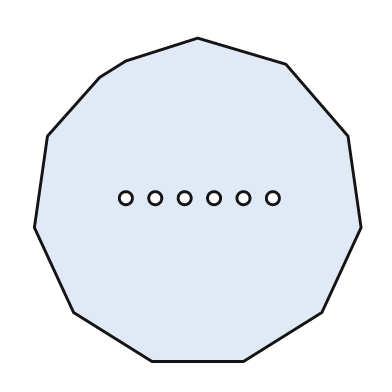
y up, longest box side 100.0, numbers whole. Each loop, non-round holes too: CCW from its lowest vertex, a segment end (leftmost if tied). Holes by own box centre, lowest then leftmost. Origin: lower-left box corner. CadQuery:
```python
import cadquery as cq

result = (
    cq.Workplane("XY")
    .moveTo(36.0, 0.0)
    .lineTo(64.0, 0.0)
    .lineTo(88.0, 15.0)
    .lineTo(100.0, 41.0)
    .lineTo(96.0, 69.0)
    .lineTo(77.0, 91.0)
    .lineTo(50.0, 99.0)
    .lineTo(28.0, 92.0)
    .lineTo(20.0, 87.0)
    .lineTo(4.0, 69.0)
    .lineTo(0.0, 41.0)
    .lineTo(12.0, 15.0)
    .close()
    .moveTo(28.0, 50.0)
    .circle(2.0)
    .moveTo(37.0, 50.0)
    .circle(2.0)
    .moveTo(46.0, 50.0)
    .circle(2.0)
    .moveTo(55.0, 50.0)
    .circle(2.0)
    .moveTo(64.0, 50.0)
    .circle(2.0)
    .moveTo(73.0, 50.0)
    .circle(2.0)
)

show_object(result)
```